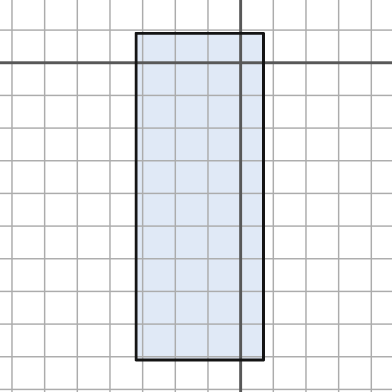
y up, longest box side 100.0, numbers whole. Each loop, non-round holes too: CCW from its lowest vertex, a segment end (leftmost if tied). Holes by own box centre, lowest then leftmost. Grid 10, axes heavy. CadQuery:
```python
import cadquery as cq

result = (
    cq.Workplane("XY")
    .moveTo(-32.0, -91.0)
    .lineTo(7.0, -91.0)
    .lineTo(7.0, 9.0)
    .lineTo(-32.0, 9.0)
    .close()
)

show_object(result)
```